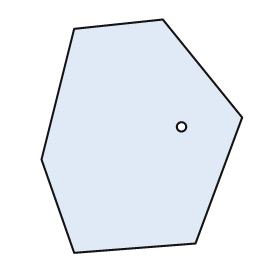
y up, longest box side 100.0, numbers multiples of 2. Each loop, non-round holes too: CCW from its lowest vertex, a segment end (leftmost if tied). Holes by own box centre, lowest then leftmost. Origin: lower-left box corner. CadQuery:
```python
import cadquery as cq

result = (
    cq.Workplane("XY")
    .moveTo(14.0, 0.0)
    .lineTo(66.0, 4.0)
    .lineTo(86.0, 58.0)
    .lineTo(52.0, 100.0)
    .lineTo(14.0, 96.0)
    .lineTo(0.0, 40.0)
    .close()
    .moveTo(60.0, 54.0)
    .circle(2.0)
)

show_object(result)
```